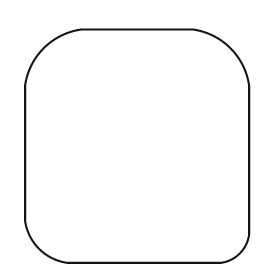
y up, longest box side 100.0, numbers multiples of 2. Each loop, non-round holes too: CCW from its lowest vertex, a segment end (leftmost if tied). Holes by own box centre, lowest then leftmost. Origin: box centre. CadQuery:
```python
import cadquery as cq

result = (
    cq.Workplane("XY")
    .moveTo(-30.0, -50.0)
    .lineTo(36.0, -50.0)
    .threePointArc((44.0, -46.0), (48.0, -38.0))
    .lineTo(48.0, 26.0)
    .threePointArc((40.0, 42.0), (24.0, 50.0))
    .lineTo(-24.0, 50.0)
    .threePointArc((-40.0, 42.0), (-48.0, 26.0))
    .lineTo(-48.0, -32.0)
    .threePointArc((-42.0, -44.0), (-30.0, -50.0))
    .close()
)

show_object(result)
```